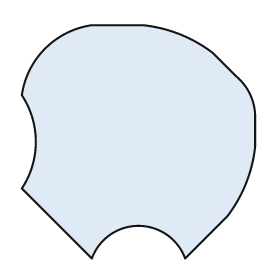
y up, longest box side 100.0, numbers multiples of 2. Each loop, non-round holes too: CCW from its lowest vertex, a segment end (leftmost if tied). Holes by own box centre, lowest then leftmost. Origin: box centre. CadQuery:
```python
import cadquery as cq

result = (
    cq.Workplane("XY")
    .moveTo(-20.0, -50.0)
    .threePointArc((0.0, -36.0), (20.0, -50.0))
    .lineTo(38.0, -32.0)
    .threePointArc((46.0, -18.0), (50.0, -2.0))
    .lineTo(50.0, 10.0)
    .threePointArc((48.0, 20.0), (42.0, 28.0))
    .lineTo(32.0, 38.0)
    .threePointArc((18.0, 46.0), (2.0, 50.0))
    .lineTo(-20.0, 50.0)
    .threePointArc((-40.0, 40.0), (-50.0, 20.0))
    .threePointArc((-44.0, 0.0), (-50.0, -20.0))
    .close()
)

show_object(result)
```